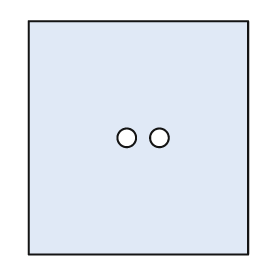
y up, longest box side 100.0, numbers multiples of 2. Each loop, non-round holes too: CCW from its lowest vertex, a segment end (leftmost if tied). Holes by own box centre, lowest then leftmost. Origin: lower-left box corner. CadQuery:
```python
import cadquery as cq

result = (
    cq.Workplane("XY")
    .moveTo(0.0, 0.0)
    .lineTo(94.0, 0.0)
    .lineTo(94.0, 100.0)
    .lineTo(0.0, 100.0)
    .close()
    .moveTo(42.0, 50.0)
    .circle(4.0)
    .moveTo(56.0, 50.0)
    .circle(4.0)
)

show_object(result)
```